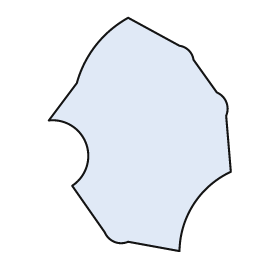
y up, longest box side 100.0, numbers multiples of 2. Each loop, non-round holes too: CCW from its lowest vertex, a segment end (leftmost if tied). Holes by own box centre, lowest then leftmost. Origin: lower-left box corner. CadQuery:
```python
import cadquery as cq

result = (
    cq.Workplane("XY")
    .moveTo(56.0, 0.0)
    .threePointArc((62.0, 20.0), (78.0, 34.0))
    .lineTo(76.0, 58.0)
    .threePointArc((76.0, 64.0), (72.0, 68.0))
    .lineTo(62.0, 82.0)
    .threePointArc((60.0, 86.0), (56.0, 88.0))
    .lineTo(34.0, 100.0)
    .threePointArc((20.0, 88.0), (12.0, 72.0))
    .lineTo(0.0, 56.0)
    .threePointArc((16.0, 46.0), (10.0, 28.0))
    .lineTo(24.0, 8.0)
    .threePointArc((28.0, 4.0), (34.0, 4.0))
    .close()
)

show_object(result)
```